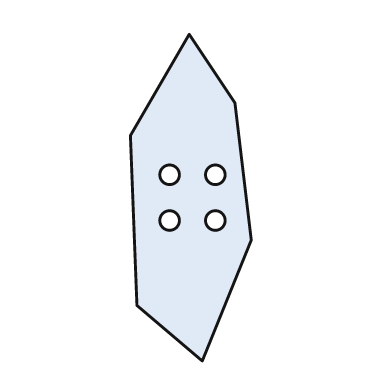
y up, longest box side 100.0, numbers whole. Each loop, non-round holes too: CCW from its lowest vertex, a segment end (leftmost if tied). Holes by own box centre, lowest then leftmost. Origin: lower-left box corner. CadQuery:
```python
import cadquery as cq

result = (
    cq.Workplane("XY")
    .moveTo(22.0, 0.0)
    .lineTo(37.0, 37.0)
    .lineTo(32.0, 79.0)
    .lineTo(18.0, 100.0)
    .lineTo(0.0, 69.0)
    .lineTo(2.0, 17.0)
    .close()
    .moveTo(12.0, 43.0)
    .circle(3.0)
    .moveTo(26.0, 43.0)
    .circle(3.0)
    .moveTo(12.0, 57.0)
    .circle(3.0)
    .moveTo(26.0, 57.0)
    .circle(3.0)
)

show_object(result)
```